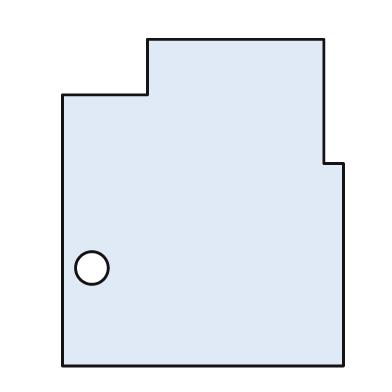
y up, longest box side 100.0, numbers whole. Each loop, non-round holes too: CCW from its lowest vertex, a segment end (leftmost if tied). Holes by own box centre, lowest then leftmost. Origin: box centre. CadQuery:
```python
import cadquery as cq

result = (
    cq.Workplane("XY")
    .moveTo(-43.0, -50.0)
    .lineTo(43.0, -50.0)
    .lineTo(43.0, 12.0)
    .lineTo(37.0, 12.0)
    .lineTo(37.0, 50.0)
    .lineTo(-17.0, 50.0)
    .lineTo(-17.0, 33.0)
    .lineTo(-43.0, 33.0)
    .close()
    .moveTo(-34.0, -20.0)
    .circle(5.0)
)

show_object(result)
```